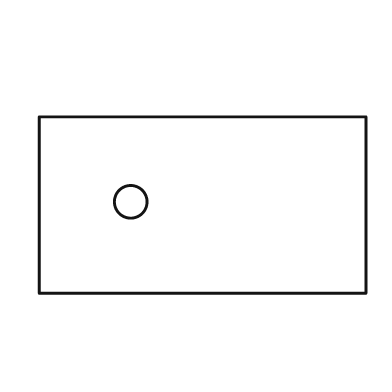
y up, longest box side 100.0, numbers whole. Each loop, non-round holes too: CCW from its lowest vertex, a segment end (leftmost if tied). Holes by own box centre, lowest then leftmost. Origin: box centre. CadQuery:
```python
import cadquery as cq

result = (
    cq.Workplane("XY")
    .moveTo(-50.0, -27.0)
    .lineTo(50.0, -27.0)
    .lineTo(50.0, 27.0)
    .lineTo(-50.0, 27.0)
    .close()
    .moveTo(-22.0, 1.0)
    .circle(5.0)
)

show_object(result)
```